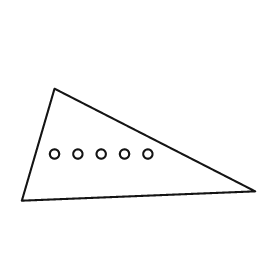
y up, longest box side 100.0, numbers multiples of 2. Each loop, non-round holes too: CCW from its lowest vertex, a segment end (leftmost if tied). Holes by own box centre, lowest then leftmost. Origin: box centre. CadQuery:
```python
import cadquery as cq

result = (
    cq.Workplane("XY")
    .moveTo(-50.0, -24.0)
    .lineTo(50.0, -20.0)
    .lineTo(-36.0, 24.0)
    .close()
    .moveTo(-36.0, -4.0)
    .circle(2.0)
    .moveTo(-26.0, -4.0)
    .circle(2.0)
    .moveTo(-16.0, -4.0)
    .circle(2.0)
    .moveTo(-6.0, -4.0)
    .circle(2.0)
    .moveTo(4.0, -4.0)
    .circle(2.0)
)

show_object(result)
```